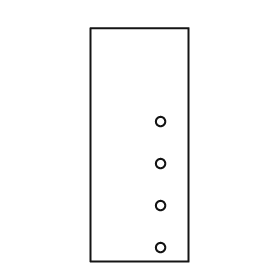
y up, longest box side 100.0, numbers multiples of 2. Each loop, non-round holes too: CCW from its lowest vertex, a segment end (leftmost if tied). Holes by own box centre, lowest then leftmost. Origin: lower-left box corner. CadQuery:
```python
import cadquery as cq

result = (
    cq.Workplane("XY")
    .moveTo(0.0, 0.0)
    .lineTo(42.0, 0.0)
    .lineTo(42.0, 100.0)
    .lineTo(0.0, 100.0)
    .close()
    .moveTo(30.0, 6.0)
    .circle(2.0)
    .moveTo(30.0, 24.0)
    .circle(2.0)
    .moveTo(30.0, 42.0)
    .circle(2.0)
    .moveTo(30.0, 60.0)
    .circle(2.0)
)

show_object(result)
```